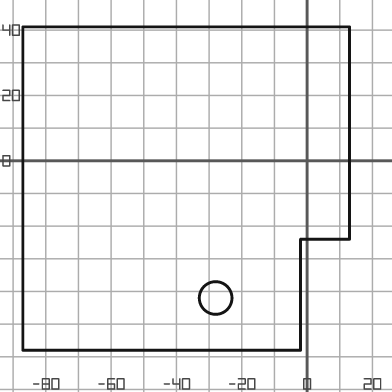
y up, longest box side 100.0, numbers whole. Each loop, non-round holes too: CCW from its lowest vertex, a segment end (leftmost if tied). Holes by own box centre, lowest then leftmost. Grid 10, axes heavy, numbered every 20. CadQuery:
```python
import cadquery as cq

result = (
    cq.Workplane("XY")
    .moveTo(-87.0, -58.0)
    .lineTo(-2.0, -58.0)
    .lineTo(-2.0, -24.0)
    .lineTo(13.0, -24.0)
    .lineTo(13.0, 41.0)
    .lineTo(-87.0, 41.0)
    .close()
    .moveTo(-28.0, -42.0)
    .circle(5.0)
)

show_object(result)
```